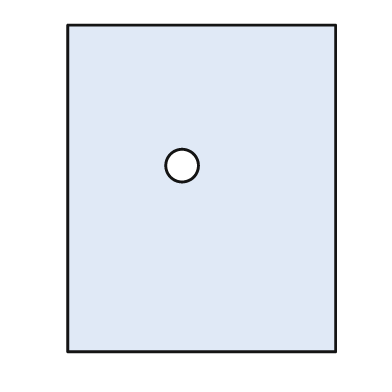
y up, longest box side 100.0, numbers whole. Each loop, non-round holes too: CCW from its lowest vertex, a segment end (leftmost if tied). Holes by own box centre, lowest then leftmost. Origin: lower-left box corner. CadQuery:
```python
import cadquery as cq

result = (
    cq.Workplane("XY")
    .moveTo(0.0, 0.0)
    .lineTo(82.0, 0.0)
    .lineTo(82.0, 100.0)
    .lineTo(0.0, 100.0)
    .close()
    .moveTo(35.0, 57.0)
    .circle(5.0)
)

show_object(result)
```